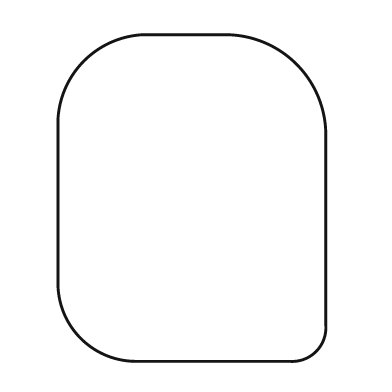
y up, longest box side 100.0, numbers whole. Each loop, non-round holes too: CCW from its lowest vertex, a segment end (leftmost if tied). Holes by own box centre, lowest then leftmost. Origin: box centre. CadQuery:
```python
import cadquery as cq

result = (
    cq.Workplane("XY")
    .moveTo(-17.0, -50.0)
    .lineTo(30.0, -50.0)
    .threePointArc((38.0, -47.0), (41.0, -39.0))
    .lineTo(41.0, 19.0)
    .threePointArc((32.0, 41.0), (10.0, 50.0))
    .lineTo(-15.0, 50.0)
    .threePointArc((-33.0, 42.0), (-41.0, 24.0))
    .lineTo(-41.0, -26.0)
    .threePointArc((-34.0, -43.0), (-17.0, -50.0))
    .close()
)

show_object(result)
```